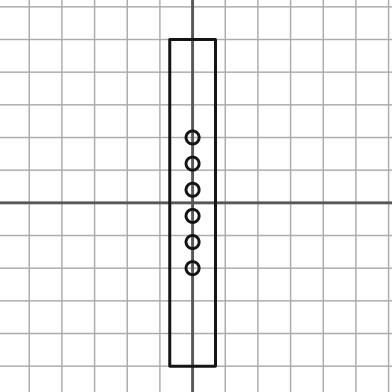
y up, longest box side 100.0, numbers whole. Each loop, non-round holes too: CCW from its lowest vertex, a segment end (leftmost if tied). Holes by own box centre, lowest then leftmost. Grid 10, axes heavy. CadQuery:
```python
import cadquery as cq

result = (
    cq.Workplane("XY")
    .moveTo(-7.0, -50.0)
    .lineTo(7.0, -50.0)
    .lineTo(7.0, 50.0)
    .lineTo(-7.0, 50.0)
    .close()
    .moveTo(0.0, -20.0)
    .circle(2.0)
    .moveTo(0.0, -12.0)
    .circle(2.0)
    .moveTo(0.0, -4.0)
    .circle(2.0)
    .moveTo(0.0, 4.0)
    .circle(2.0)
    .moveTo(0.0, 12.0)
    .circle(2.0)
    .moveTo(0.0, 20.0)
    .circle(2.0)
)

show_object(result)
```